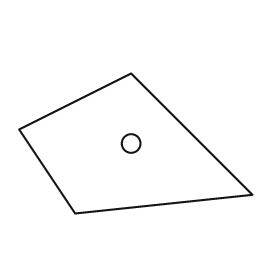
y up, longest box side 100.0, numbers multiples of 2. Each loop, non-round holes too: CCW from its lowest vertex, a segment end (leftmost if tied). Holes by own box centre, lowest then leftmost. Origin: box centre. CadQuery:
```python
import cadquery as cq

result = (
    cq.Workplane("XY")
    .moveTo(-26.0, -30.0)
    .lineTo(50.0, -22.0)
    .lineTo(-2.0, 30.0)
    .lineTo(-50.0, 6.0)
    .close()
    .moveTo(-2.0, 0.0)
    .circle(4.0)
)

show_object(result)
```